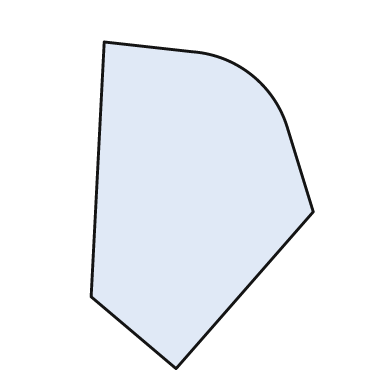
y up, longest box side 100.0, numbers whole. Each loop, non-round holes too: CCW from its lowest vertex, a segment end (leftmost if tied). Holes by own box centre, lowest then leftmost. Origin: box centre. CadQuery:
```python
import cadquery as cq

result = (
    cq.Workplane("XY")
    .moveTo(-8.0, -50.0)
    .lineTo(34.0, -2.0)
    .lineTo(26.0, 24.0)
    .threePointArc((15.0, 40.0), (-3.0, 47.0))
    .lineTo(-30.0, 50.0)
    .lineTo(-34.0, -28.0)
    .close()
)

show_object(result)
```